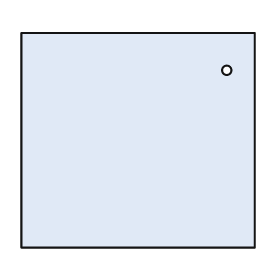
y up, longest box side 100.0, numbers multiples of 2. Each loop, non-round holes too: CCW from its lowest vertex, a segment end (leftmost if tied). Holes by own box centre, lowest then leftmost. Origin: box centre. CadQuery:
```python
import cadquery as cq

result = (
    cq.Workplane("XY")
    .moveTo(-50.0, -46.0)
    .lineTo(50.0, -46.0)
    .lineTo(50.0, 46.0)
    .lineTo(-50.0, 46.0)
    .close()
    .moveTo(38.0, 30.0)
    .circle(2.0)
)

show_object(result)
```